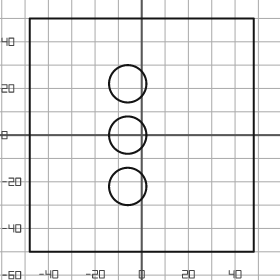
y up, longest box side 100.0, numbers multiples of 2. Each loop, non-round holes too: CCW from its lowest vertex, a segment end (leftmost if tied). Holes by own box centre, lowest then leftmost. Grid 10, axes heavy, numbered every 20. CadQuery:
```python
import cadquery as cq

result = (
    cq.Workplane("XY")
    .moveTo(-48.0, -50.0)
    .lineTo(48.0, -50.0)
    .lineTo(48.0, 50.0)
    .lineTo(-48.0, 50.0)
    .close()
    .moveTo(-6.0, -22.0)
    .circle(8.0)
    .moveTo(-6.0, 0.0)
    .circle(8.0)
    .moveTo(-6.0, 22.0)
    .circle(8.0)
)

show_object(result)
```